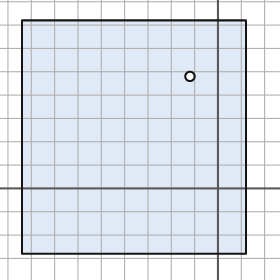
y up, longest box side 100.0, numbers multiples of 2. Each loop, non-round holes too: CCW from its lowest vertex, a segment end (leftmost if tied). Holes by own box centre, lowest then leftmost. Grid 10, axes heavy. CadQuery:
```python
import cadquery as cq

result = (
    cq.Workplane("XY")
    .moveTo(-84.0, -28.0)
    .lineTo(12.0, -28.0)
    .lineTo(12.0, 72.0)
    .lineTo(-84.0, 72.0)
    .close()
    .moveTo(-12.0, 48.0)
    .circle(2.0)
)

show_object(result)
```